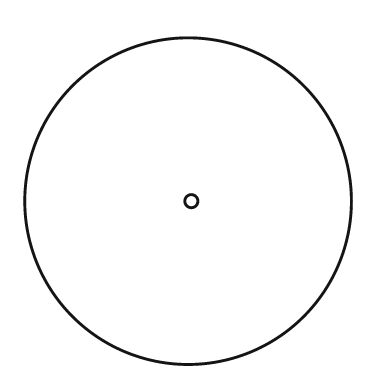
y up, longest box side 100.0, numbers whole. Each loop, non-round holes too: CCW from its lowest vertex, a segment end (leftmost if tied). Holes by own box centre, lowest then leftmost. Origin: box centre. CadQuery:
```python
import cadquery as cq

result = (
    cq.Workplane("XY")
    .moveTo(0.0, 0.0)
    .circle(50.0)
    .moveTo(1.0, 0.0)
    .circle(2.0)
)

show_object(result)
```